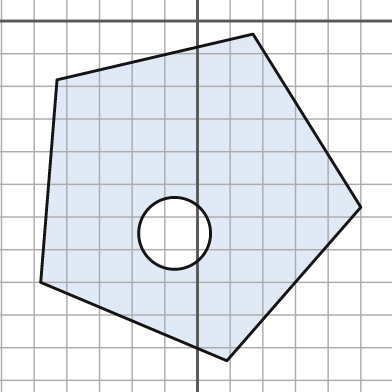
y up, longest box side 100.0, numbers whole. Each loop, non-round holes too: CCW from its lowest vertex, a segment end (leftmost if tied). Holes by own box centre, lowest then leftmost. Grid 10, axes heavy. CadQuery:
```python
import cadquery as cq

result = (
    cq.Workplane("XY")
    .moveTo(9.0, -104.0)
    .lineTo(50.0, -57.0)
    .lineTo(17.0, -4.0)
    .lineTo(-43.0, -18.0)
    .lineTo(-48.0, -80.0)
    .close()
    .moveTo(-7.0, -65.0)
    .circle(11.0)
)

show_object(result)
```